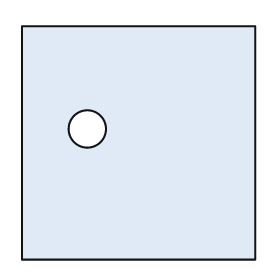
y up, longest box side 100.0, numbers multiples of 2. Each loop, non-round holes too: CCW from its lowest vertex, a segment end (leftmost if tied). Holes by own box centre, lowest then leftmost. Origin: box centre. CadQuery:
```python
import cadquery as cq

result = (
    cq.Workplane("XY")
    .moveTo(-50.0, -50.0)
    .lineTo(50.0, -50.0)
    .lineTo(50.0, 50.0)
    .lineTo(-50.0, 50.0)
    .close()
    .moveTo(-22.0, 6.0)
    .circle(8.0)
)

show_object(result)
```